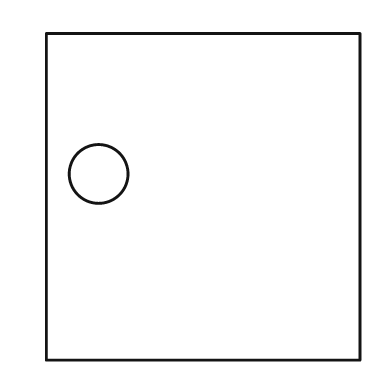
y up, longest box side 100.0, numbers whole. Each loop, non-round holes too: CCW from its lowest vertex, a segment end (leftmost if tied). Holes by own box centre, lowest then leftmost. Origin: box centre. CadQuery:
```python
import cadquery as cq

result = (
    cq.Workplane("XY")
    .moveTo(-48.0, -50.0)
    .lineTo(48.0, -50.0)
    .lineTo(48.0, 50.0)
    .lineTo(-48.0, 50.0)
    .close()
    .moveTo(-32.0, 7.0)
    .circle(9.0)
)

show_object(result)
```